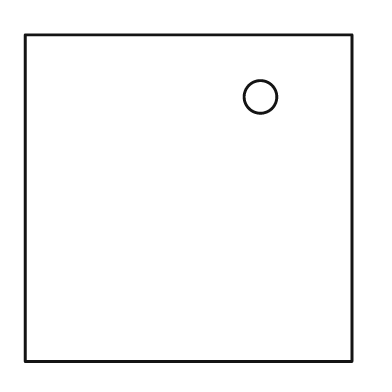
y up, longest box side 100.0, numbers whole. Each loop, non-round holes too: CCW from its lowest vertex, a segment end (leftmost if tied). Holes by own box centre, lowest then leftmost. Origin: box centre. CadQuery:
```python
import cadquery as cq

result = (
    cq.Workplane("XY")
    .moveTo(-50.0, -50.0)
    .lineTo(50.0, -50.0)
    .lineTo(50.0, 50.0)
    .lineTo(-50.0, 50.0)
    .close()
    .moveTo(22.0, 31.0)
    .circle(5.0)
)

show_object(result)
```